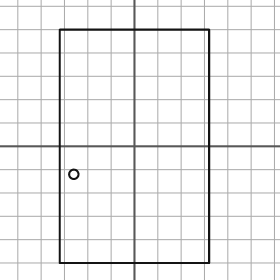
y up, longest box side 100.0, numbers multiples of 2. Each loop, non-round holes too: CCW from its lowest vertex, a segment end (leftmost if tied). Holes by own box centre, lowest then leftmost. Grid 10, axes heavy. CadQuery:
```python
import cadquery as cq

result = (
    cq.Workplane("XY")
    .moveTo(-32.0, -50.0)
    .lineTo(32.0, -50.0)
    .lineTo(32.0, 50.0)
    .lineTo(-32.0, 50.0)
    .close()
    .moveTo(-26.0, -12.0)
    .circle(2.0)
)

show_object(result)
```